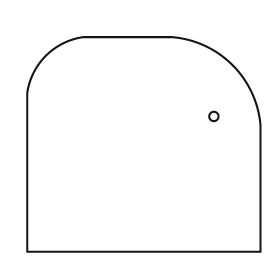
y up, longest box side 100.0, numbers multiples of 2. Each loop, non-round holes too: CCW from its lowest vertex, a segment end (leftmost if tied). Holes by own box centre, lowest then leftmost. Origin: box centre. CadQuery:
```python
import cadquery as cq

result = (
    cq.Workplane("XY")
    .moveTo(-50.0, -46.0)
    .lineTo(50.0, -46.0)
    .lineTo(50.0, 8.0)
    .threePointArc((38.0, 34.0), (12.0, 46.0))
    .lineTo(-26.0, 46.0)
    .threePointArc((-42.0, 38.0), (-50.0, 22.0))
    .close()
    .moveTo(30.0, 12.0)
    .circle(2.0)
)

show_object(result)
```